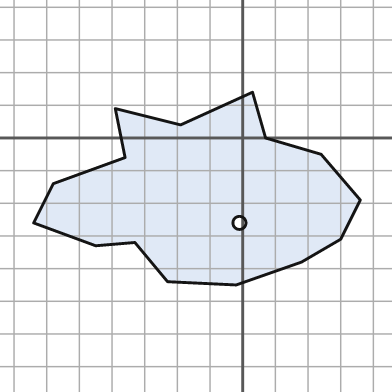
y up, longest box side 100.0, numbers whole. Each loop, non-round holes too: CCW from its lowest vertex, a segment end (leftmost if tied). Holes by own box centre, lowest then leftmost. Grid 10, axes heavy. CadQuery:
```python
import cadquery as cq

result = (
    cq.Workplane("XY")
    .moveTo(-2.0, -45.0)
    .lineTo(18.0, -38.0)
    .lineTo(30.0, -31.0)
    .lineTo(36.0, -19.0)
    .lineTo(24.0, -5.0)
    .lineTo(7.0, 0.0)
    .lineTo(3.0, 14.0)
    .lineTo(-19.0, 4.0)
    .lineTo(-39.0, 9.0)
    .lineTo(-36.0, -6.0)
    .lineTo(-58.0, -14.0)
    .lineTo(-64.0, -26.0)
    .lineTo(-45.0, -33.0)
    .lineTo(-33.0, -32.0)
    .lineTo(-23.0, -44.0)
    .close()
    .moveTo(-1.0, -26.0)
    .circle(2.0)
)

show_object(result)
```